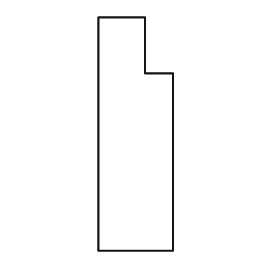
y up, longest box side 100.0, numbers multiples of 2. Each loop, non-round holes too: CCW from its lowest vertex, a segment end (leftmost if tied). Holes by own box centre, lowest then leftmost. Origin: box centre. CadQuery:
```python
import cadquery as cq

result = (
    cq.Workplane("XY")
    .moveTo(-16.0, -50.0)
    .lineTo(16.0, -50.0)
    .lineTo(16.0, 26.0)
    .lineTo(4.0, 26.0)
    .lineTo(4.0, 50.0)
    .lineTo(-16.0, 50.0)
    .close()
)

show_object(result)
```